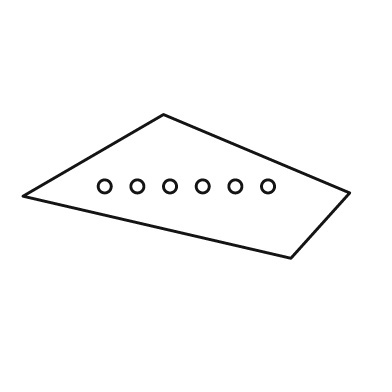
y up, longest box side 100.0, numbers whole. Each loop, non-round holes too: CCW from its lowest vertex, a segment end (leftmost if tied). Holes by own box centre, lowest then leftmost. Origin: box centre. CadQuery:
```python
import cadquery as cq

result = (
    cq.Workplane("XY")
    .moveTo(32.0, -22.0)
    .lineTo(50.0, -2.0)
    .lineTo(-7.0, 22.0)
    .lineTo(-50.0, -3.0)
    .close()
    .moveTo(-25.0, 0.0)
    .circle(2.0)
    .moveTo(-15.0, 0.0)
    .circle(2.0)
    .moveTo(-5.0, 0.0)
    .circle(2.0)
    .moveTo(5.0, 0.0)
    .circle(2.0)
    .moveTo(15.0, 0.0)
    .circle(2.0)
    .moveTo(25.0, 0.0)
    .circle(2.0)
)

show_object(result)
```